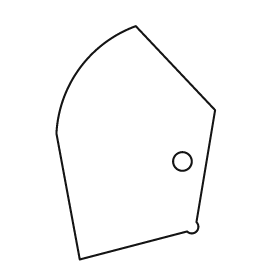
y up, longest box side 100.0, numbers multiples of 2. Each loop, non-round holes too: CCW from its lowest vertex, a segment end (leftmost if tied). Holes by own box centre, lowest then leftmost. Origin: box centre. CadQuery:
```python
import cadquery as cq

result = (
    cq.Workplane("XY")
    .moveTo(-24.0, -50.0)
    .lineTo(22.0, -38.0)
    .threePointArc((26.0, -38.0), (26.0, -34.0))
    .lineTo(34.0, 14.0)
    .lineTo(0.0, 50.0)
    .threePointArc((-24.0, 32.0), (-34.0, 4.0))
    .close()
    .moveTo(20.0, -8.0)
    .circle(4.0)
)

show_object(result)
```